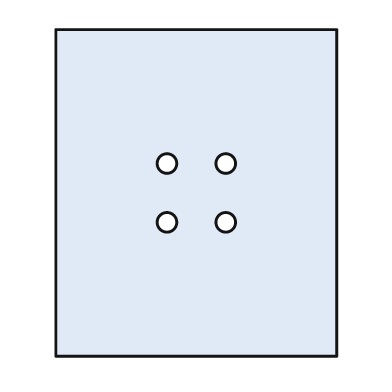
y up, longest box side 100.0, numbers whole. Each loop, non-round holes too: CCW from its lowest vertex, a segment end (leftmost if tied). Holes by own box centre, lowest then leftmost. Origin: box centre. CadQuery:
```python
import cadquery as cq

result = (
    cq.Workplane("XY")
    .moveTo(-43.0, -50.0)
    .lineTo(43.0, -50.0)
    .lineTo(43.0, 50.0)
    .lineTo(-43.0, 50.0)
    .close()
    .moveTo(-9.0, -9.0)
    .circle(3.0)
    .moveTo(9.0, -9.0)
    .circle(3.0)
    .moveTo(-9.0, 9.0)
    .circle(3.0)
    .moveTo(9.0, 9.0)
    .circle(3.0)
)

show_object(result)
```